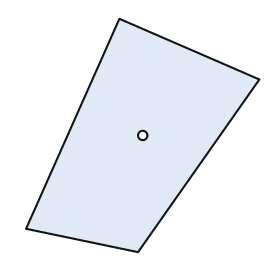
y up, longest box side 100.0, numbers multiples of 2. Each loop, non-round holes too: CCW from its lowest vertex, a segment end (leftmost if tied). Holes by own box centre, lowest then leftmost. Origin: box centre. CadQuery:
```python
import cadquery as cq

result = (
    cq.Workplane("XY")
    .moveTo(-2.0, -50.0)
    .lineTo(50.0, 24.0)
    .lineTo(-10.0, 50.0)
    .lineTo(-50.0, -40.0)
    .close()
    .moveTo(0.0, 0.0)
    .circle(2.0)
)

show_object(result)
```